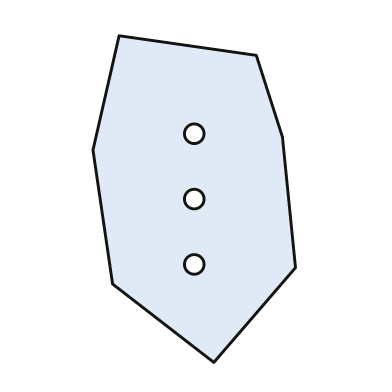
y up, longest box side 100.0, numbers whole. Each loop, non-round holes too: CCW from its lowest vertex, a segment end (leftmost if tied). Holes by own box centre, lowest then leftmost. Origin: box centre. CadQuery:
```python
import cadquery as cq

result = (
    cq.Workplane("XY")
    .moveTo(6.0, -50.0)
    .lineTo(31.0, -21.0)
    .lineTo(27.0, 19.0)
    .lineTo(19.0, 44.0)
    .lineTo(-23.0, 50.0)
    .lineTo(-31.0, 15.0)
    .lineTo(-25.0, -26.0)
    .close()
    .moveTo(0.0, -20.0)
    .circle(3.0)
    .moveTo(0.0, 0.0)
    .circle(3.0)
    .moveTo(0.0, 20.0)
    .circle(3.0)
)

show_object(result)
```